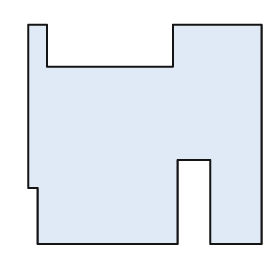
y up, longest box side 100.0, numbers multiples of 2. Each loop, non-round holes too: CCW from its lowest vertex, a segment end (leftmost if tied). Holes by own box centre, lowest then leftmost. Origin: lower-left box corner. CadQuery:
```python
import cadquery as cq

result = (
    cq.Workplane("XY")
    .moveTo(4.0, 0.0)
    .lineTo(64.0, 0.0)
    .lineTo(64.0, 36.0)
    .lineTo(78.0, 36.0)
    .lineTo(78.0, 0.0)
    .lineTo(100.0, 0.0)
    .lineTo(100.0, 94.0)
    .lineTo(62.0, 94.0)
    .lineTo(62.0, 76.0)
    .lineTo(8.0, 76.0)
    .lineTo(8.0, 94.0)
    .lineTo(0.0, 94.0)
    .lineTo(0.0, 24.0)
    .lineTo(4.0, 24.0)
    .close()
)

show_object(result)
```